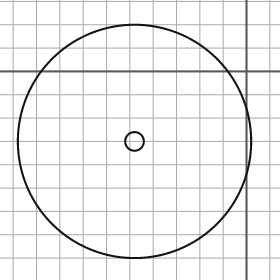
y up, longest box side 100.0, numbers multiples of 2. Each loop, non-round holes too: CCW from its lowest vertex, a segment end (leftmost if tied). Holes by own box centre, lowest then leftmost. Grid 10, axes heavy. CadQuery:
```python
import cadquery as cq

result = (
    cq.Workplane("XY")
    .moveTo(-48.0, -30.0)
    .circle(50.0)
    .moveTo(-48.0, -30.0)
    .circle(4.0)
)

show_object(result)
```